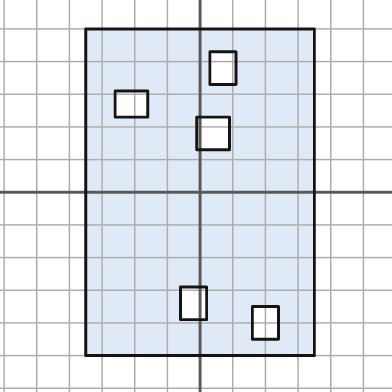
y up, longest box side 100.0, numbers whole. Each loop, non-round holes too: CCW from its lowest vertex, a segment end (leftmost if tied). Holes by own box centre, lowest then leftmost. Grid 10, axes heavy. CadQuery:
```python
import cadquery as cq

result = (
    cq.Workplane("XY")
    .moveTo(-35.0, -50.0)
    .lineTo(35.0, -50.0)
    .lineTo(35.0, 50.0)
    .lineTo(-35.0, 50.0)
    .close()
    .moveTo(16.0, -45.0)
    .lineTo(24.0, -45.0)
    .lineTo(24.0, -35.0)
    .lineTo(16.0, -35.0)
    .close()
    .moveTo(-6.0, -39.0)
    .lineTo(2.0, -39.0)
    .lineTo(2.0, -29.0)
    .lineTo(-6.0, -29.0)
    .close()
    .moveTo(-1.0, 13.0)
    .lineTo(9.0, 13.0)
    .lineTo(9.0, 23.0)
    .lineTo(-1.0, 23.0)
    .close()
    .moveTo(-26.0, 23.0)
    .lineTo(-16.0, 23.0)
    .lineTo(-16.0, 31.0)
    .lineTo(-26.0, 31.0)
    .close()
    .moveTo(3.0, 33.0)
    .lineTo(11.0, 33.0)
    .lineTo(11.0, 43.0)
    .lineTo(3.0, 43.0)
    .close()
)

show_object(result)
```